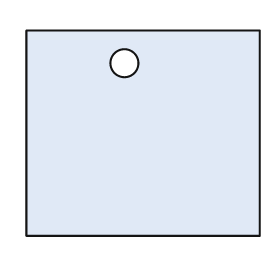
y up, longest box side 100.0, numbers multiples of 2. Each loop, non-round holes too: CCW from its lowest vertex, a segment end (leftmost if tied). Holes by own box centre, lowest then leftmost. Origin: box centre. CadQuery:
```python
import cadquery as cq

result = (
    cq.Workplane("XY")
    .moveTo(-50.0, -44.0)
    .lineTo(50.0, -44.0)
    .lineTo(50.0, 44.0)
    .lineTo(-50.0, 44.0)
    .close()
    .moveTo(-8.0, 30.0)
    .circle(6.0)
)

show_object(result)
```